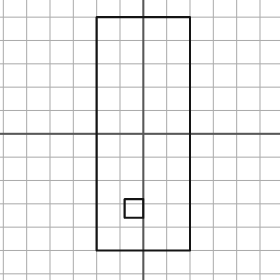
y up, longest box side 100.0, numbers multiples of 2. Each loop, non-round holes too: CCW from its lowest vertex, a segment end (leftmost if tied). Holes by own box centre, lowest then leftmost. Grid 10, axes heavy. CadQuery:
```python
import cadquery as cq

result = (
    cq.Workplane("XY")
    .moveTo(-20.0, -50.0)
    .lineTo(20.0, -50.0)
    .lineTo(20.0, 50.0)
    .lineTo(-20.0, 50.0)
    .close()
    .moveTo(-8.0, -36.0)
    .lineTo(0.0, -36.0)
    .lineTo(0.0, -28.0)
    .lineTo(-8.0, -28.0)
    .close()
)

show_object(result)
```